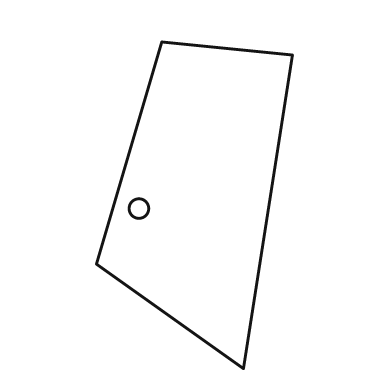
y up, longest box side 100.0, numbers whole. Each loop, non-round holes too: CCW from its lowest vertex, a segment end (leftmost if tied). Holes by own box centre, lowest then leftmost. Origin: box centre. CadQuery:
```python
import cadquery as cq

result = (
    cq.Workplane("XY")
    .moveTo(15.0, -50.0)
    .lineTo(30.0, 46.0)
    .lineTo(-10.0, 50.0)
    .lineTo(-30.0, -18.0)
    .close()
    .moveTo(-17.0, -1.0)
    .circle(3.0)
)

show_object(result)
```